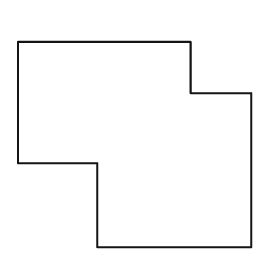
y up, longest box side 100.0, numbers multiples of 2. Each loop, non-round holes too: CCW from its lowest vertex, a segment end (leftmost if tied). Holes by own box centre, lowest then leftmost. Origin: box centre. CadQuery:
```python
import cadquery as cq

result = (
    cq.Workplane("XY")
    .moveTo(-16.0, -44.0)
    .lineTo(50.0, -44.0)
    .lineTo(50.0, 22.0)
    .lineTo(24.0, 22.0)
    .lineTo(24.0, 44.0)
    .lineTo(-50.0, 44.0)
    .lineTo(-50.0, -8.0)
    .lineTo(-16.0, -8.0)
    .close()
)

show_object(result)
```